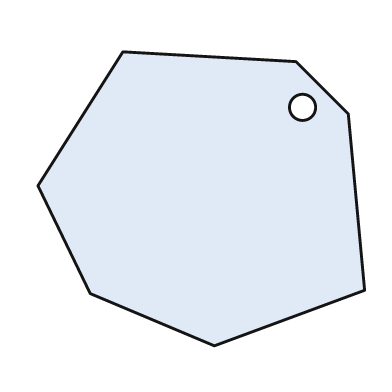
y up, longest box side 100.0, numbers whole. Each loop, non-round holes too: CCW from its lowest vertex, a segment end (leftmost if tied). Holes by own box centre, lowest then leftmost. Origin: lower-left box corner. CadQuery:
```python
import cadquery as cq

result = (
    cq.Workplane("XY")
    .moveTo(54.0, 0.0)
    .lineTo(100.0, 17.0)
    .lineTo(95.0, 71.0)
    .lineTo(79.0, 87.0)
    .lineTo(26.0, 90.0)
    .lineTo(0.0, 49.0)
    .lineTo(16.0, 16.0)
    .close()
    .moveTo(81.0, 73.0)
    .circle(4.0)
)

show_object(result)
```